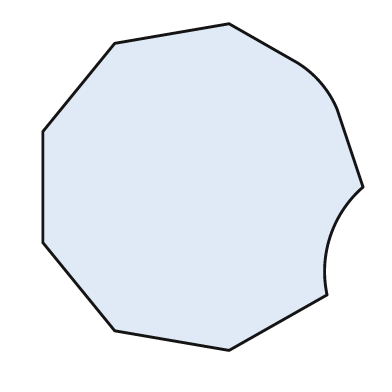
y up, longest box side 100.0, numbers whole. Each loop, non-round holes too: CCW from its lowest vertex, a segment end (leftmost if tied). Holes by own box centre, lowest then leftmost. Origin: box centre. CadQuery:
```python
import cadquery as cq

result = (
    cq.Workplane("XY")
    .moveTo(8.0, -50.0)
    .lineTo(38.0, -33.0)
    .threePointArc((39.0, -15.0), (49.0, 0.0))
    .lineTo(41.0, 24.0)
    .threePointArc((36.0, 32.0), (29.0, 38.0))
    .lineTo(8.0, 50.0)
    .lineTo(-27.0, 44.0)
    .lineTo(-49.0, 17.0)
    .lineTo(-49.0, -17.0)
    .lineTo(-27.0, -44.0)
    .close()
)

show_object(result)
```